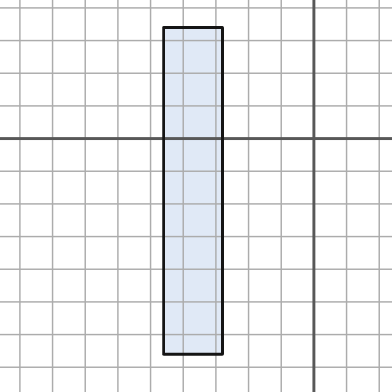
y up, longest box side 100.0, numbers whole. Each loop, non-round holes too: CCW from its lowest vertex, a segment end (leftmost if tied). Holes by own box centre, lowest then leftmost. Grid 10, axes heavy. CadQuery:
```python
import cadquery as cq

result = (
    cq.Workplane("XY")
    .moveTo(-46.0, -66.0)
    .lineTo(-28.0, -66.0)
    .lineTo(-28.0, 34.0)
    .lineTo(-46.0, 34.0)
    .close()
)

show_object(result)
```